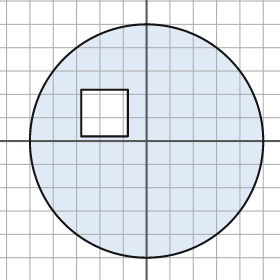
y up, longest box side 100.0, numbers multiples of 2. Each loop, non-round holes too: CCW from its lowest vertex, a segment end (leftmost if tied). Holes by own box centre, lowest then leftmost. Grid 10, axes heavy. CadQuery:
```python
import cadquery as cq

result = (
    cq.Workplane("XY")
    .moveTo(0.0, 0.0)
    .circle(50.0)
    .moveTo(-28.0, 2.0)
    .lineTo(-8.0, 2.0)
    .lineTo(-8.0, 22.0)
    .lineTo(-28.0, 22.0)
    .close()
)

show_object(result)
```